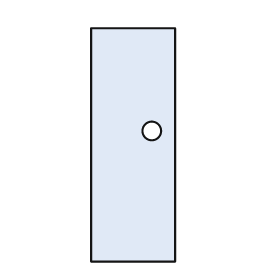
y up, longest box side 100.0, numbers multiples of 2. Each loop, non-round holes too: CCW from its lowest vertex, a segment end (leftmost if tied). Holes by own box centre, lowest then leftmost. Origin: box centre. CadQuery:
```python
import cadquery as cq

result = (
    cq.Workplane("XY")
    .moveTo(-18.0, -50.0)
    .lineTo(18.0, -50.0)
    .lineTo(18.0, 50.0)
    .lineTo(-18.0, 50.0)
    .close()
    .moveTo(8.0, 6.0)
    .circle(4.0)
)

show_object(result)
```